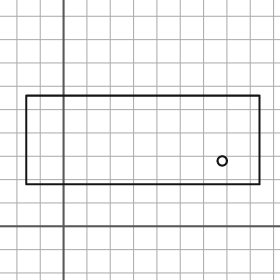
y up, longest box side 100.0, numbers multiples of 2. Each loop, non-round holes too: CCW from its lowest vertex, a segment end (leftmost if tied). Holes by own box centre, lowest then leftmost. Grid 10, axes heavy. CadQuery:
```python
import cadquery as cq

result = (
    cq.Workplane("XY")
    .moveTo(-16.0, 18.0)
    .lineTo(84.0, 18.0)
    .lineTo(84.0, 56.0)
    .lineTo(-16.0, 56.0)
    .close()
    .moveTo(68.0, 28.0)
    .circle(2.0)
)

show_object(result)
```